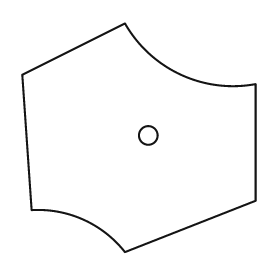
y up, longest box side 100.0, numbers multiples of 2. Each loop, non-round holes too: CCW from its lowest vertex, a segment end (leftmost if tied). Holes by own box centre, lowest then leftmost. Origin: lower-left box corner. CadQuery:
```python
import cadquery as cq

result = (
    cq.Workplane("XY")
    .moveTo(44.0, 0.0)
    .lineTo(100.0, 22.0)
    .lineTo(100.0, 72.0)
    .threePointArc((68.0, 76.0), (44.0, 98.0))
    .lineTo(0.0, 76.0)
    .lineTo(4.0, 18.0)
    .threePointArc((26.0, 14.0), (44.0, 0.0))
    .close()
    .moveTo(54.0, 50.0)
    .circle(4.0)
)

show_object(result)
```